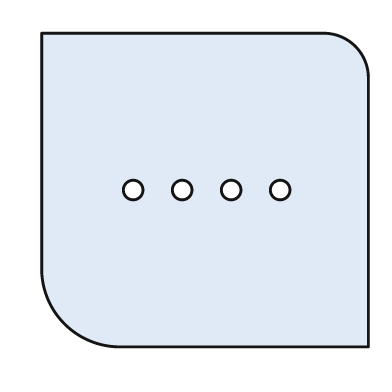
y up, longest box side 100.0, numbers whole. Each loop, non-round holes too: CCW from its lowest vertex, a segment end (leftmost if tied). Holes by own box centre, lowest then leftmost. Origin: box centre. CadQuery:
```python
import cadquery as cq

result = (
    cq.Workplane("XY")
    .moveTo(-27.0, -48.0)
    .lineTo(50.0, -48.0)
    .lineTo(50.0, 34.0)
    .threePointArc((46.0, 44.0), (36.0, 48.0))
    .lineTo(-50.0, 48.0)
    .lineTo(-50.0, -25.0)
    .threePointArc((-43.0, -41.0), (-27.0, -48.0))
    .close()
    .moveTo(-22.0, 0.0)
    .circle(3.0)
    .moveTo(-7.0, 0.0)
    .circle(3.0)
    .moveTo(8.0, 0.0)
    .circle(3.0)
    .moveTo(23.0, 0.0)
    .circle(3.0)
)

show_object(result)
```